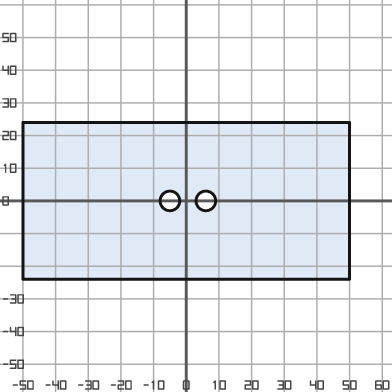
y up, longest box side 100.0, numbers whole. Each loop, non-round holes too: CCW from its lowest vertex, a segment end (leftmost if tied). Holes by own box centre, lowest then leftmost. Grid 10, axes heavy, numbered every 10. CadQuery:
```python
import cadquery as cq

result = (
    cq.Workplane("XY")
    .moveTo(-50.0, -24.0)
    .lineTo(50.0, -24.0)
    .lineTo(50.0, 24.0)
    .lineTo(-50.0, 24.0)
    .close()
    .moveTo(-5.0, 0.0)
    .circle(3.0)
    .moveTo(6.0, 0.0)
    .circle(3.0)
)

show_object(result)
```